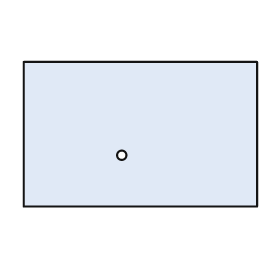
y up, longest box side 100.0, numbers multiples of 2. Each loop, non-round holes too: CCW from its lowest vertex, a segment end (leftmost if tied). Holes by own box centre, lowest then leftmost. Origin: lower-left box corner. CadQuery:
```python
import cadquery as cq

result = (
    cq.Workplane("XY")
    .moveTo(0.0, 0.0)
    .lineTo(100.0, 0.0)
    .lineTo(100.0, 62.0)
    .lineTo(0.0, 62.0)
    .close()
    .moveTo(42.0, 22.0)
    .circle(2.0)
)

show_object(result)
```